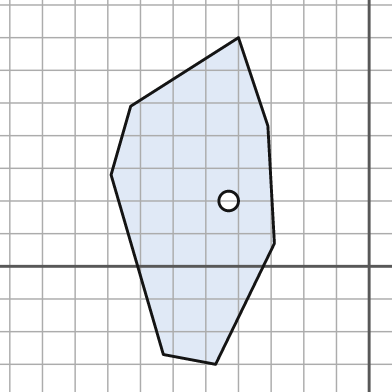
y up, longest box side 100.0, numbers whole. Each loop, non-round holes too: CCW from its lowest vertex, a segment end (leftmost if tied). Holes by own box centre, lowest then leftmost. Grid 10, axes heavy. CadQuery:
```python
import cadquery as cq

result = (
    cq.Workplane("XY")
    .moveTo(-47.0, -30.0)
    .lineTo(-29.0, 7.0)
    .lineTo(-31.0, 43.0)
    .lineTo(-40.0, 70.0)
    .lineTo(-73.0, 49.0)
    .lineTo(-79.0, 28.0)
    .lineTo(-63.0, -27.0)
    .close()
    .moveTo(-43.0, 20.0)
    .circle(3.0)
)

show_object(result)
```